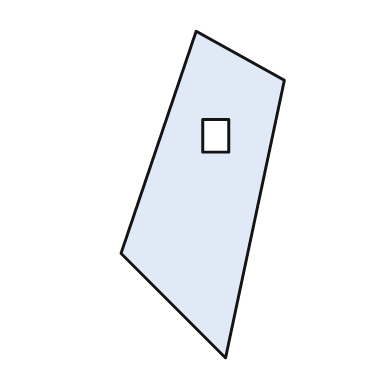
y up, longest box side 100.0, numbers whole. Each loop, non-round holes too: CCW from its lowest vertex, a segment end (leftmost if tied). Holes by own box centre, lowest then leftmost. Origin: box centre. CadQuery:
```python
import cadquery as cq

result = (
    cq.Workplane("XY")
    .moveTo(7.0, -50.0)
    .lineTo(25.0, 35.0)
    .lineTo(-2.0, 50.0)
    .lineTo(-25.0, -18.0)
    .close()
    .moveTo(0.0, 13.0)
    .lineTo(8.0, 13.0)
    .lineTo(8.0, 23.0)
    .lineTo(0.0, 23.0)
    .close()
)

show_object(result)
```